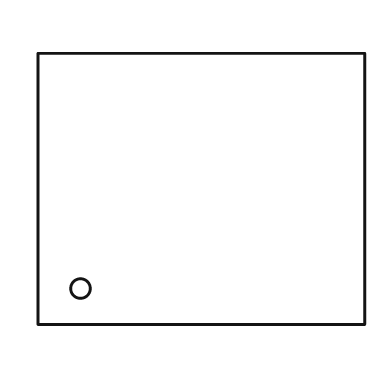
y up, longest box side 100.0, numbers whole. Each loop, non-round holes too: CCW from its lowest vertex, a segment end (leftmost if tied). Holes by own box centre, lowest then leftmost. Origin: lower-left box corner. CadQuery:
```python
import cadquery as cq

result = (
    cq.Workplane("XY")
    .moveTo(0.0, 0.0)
    .lineTo(100.0, 0.0)
    .lineTo(100.0, 83.0)
    .lineTo(0.0, 83.0)
    .close()
    .moveTo(13.0, 11.0)
    .circle(3.0)
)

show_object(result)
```